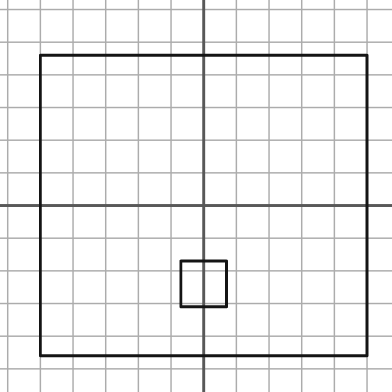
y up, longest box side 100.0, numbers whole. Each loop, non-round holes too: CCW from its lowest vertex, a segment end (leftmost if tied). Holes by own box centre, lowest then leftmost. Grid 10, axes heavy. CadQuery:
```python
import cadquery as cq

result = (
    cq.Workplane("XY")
    .moveTo(-50.0, -46.0)
    .lineTo(50.0, -46.0)
    .lineTo(50.0, 46.0)
    .lineTo(-50.0, 46.0)
    .close()
    .moveTo(-7.0, -31.0)
    .lineTo(7.0, -31.0)
    .lineTo(7.0, -17.0)
    .lineTo(-7.0, -17.0)
    .close()
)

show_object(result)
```